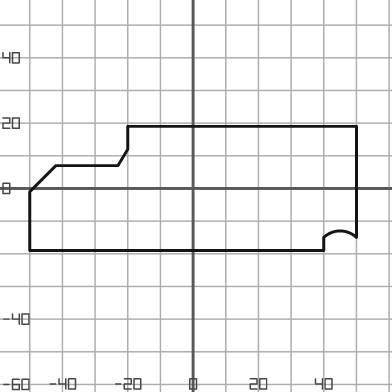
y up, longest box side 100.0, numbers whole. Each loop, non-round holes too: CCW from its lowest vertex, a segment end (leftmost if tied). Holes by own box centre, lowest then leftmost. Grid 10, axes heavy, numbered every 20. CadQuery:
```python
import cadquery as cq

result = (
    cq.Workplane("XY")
    .moveTo(-50.0, -19.0)
    .lineTo(40.0, -19.0)
    .lineTo(40.0, -15.0)
    .threePointArc((45.0, -13.0), (50.0, -15.0))
    .lineTo(50.0, 19.0)
    .lineTo(-20.0, 19.0)
    .lineTo(-20.0, 12.0)
    .lineTo(-23.0, 7.0)
    .lineTo(-42.0, 7.0)
    .lineTo(-50.0, -1.0)
    .close()
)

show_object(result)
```